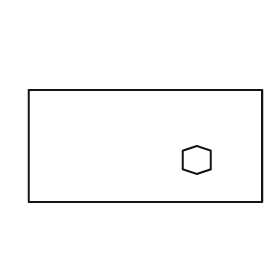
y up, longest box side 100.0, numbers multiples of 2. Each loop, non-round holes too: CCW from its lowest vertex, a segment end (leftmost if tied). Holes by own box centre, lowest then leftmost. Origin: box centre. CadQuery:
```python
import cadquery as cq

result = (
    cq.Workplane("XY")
    .moveTo(-50.0, -24.0)
    .lineTo(50.0, -24.0)
    .lineTo(50.0, 24.0)
    .lineTo(-50.0, 24.0)
    .close()
    .moveTo(22.0, -12.0)
    .lineTo(28.0, -10.0)
    .lineTo(28.0, -2.0)
    .lineTo(22.0, 0.0)
    .lineTo(16.0, -2.0)
    .lineTo(16.0, -10.0)
    .close()
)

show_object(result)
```